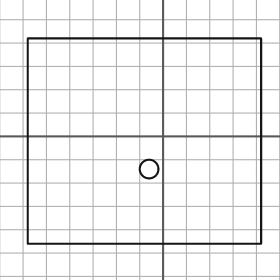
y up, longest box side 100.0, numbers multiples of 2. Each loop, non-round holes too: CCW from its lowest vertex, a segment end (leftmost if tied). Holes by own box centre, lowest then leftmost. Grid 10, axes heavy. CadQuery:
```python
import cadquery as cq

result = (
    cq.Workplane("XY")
    .moveTo(-58.0, -46.0)
    .lineTo(42.0, -46.0)
    .lineTo(42.0, 42.0)
    .lineTo(-58.0, 42.0)
    .close()
    .moveTo(-6.0, -14.0)
    .circle(4.0)
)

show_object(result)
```